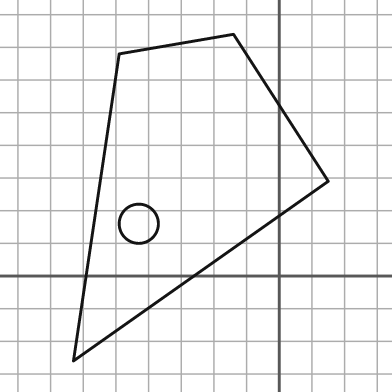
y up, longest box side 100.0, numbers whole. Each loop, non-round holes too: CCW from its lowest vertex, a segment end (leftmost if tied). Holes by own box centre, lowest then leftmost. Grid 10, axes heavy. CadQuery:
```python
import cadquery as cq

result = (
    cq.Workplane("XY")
    .moveTo(-63.0, -26.0)
    .lineTo(15.0, 29.0)
    .lineTo(-14.0, 74.0)
    .lineTo(-49.0, 68.0)
    .close()
    .moveTo(-43.0, 16.0)
    .circle(6.0)
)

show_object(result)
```